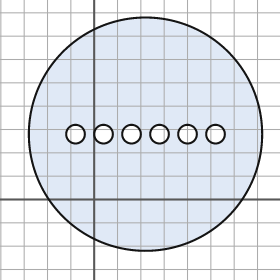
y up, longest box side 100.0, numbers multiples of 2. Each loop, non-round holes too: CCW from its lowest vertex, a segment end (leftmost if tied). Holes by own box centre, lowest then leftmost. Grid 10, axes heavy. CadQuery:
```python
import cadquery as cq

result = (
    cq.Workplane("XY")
    .moveTo(22.0, 28.0)
    .circle(50.0)
    .moveTo(-8.0, 28.0)
    .circle(4.0)
    .moveTo(4.0, 28.0)
    .circle(4.0)
    .moveTo(16.0, 28.0)
    .circle(4.0)
    .moveTo(28.0, 28.0)
    .circle(4.0)
    .moveTo(40.0, 28.0)
    .circle(4.0)
    .moveTo(52.0, 28.0)
    .circle(4.0)
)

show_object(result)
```